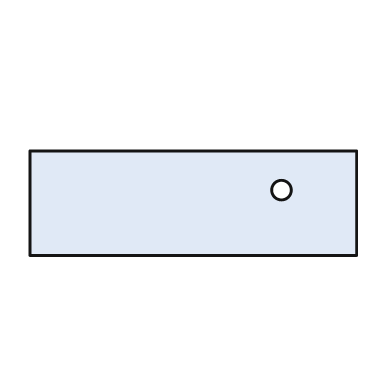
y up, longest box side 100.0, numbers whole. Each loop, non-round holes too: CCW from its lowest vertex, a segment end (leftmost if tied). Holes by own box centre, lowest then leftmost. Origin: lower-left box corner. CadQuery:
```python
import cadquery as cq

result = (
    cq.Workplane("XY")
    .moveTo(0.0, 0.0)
    .lineTo(100.0, 0.0)
    .lineTo(100.0, 32.0)
    .lineTo(0.0, 32.0)
    .close()
    .moveTo(77.0, 20.0)
    .circle(3.0)
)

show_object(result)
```